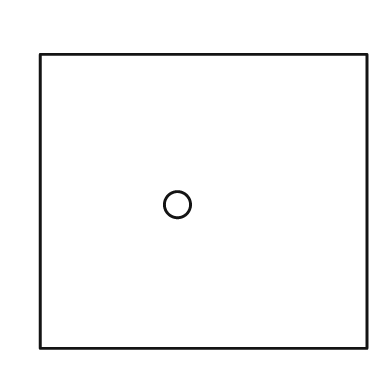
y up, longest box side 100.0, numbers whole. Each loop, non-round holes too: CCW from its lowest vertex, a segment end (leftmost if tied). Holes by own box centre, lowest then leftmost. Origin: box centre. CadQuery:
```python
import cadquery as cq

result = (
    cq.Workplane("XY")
    .moveTo(-50.0, -45.0)
    .lineTo(50.0, -45.0)
    .lineTo(50.0, 45.0)
    .lineTo(-50.0, 45.0)
    .close()
    .moveTo(-8.0, -1.0)
    .circle(4.0)
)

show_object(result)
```